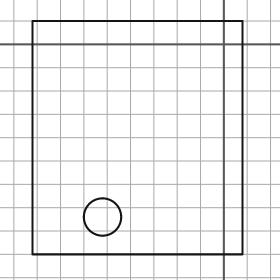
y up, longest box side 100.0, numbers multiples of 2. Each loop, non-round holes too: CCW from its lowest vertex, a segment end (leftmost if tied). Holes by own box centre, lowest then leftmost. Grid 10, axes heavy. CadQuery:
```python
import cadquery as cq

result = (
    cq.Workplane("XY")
    .moveTo(-82.0, -90.0)
    .lineTo(8.0, -90.0)
    .lineTo(8.0, 10.0)
    .lineTo(-82.0, 10.0)
    .close()
    .moveTo(-52.0, -74.0)
    .circle(8.0)
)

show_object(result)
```